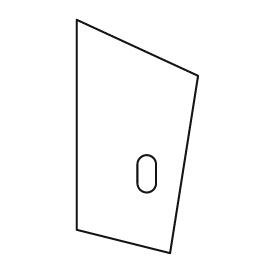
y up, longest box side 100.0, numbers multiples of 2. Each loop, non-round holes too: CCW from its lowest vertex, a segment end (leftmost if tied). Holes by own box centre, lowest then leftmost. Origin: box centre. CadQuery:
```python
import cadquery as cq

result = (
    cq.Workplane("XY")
    .moveTo(14.0, -50.0)
    .lineTo(26.0, 26.0)
    .lineTo(-26.0, 50.0)
    .lineTo(-26.0, -40.0)
    .close()
    .moveTo(0.0, -20.0)
    .threePointArc((4.0, -24.0), (8.0, -20.0))
    .lineTo(8.0, -12.0)
    .threePointArc((4.0, -8.0), (0.0, -12.0))
    .close()
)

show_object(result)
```